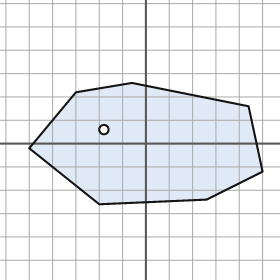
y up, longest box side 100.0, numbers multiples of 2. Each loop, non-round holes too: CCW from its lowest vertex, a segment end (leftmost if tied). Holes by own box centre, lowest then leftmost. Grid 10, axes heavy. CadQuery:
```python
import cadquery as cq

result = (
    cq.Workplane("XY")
    .moveTo(-20.0, -26.0)
    .lineTo(26.0, -24.0)
    .lineTo(50.0, -12.0)
    .lineTo(44.0, 16.0)
    .lineTo(-6.0, 26.0)
    .lineTo(-30.0, 22.0)
    .lineTo(-50.0, -2.0)
    .close()
    .moveTo(-18.0, 6.0)
    .circle(2.0)
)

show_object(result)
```